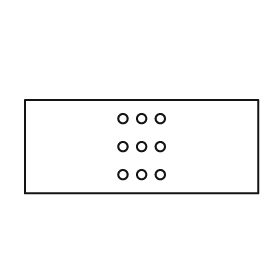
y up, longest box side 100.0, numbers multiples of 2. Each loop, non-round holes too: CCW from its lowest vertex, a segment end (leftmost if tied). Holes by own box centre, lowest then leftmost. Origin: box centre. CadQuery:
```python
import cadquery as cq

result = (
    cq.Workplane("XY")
    .moveTo(-50.0, -20.0)
    .lineTo(50.0, -20.0)
    .lineTo(50.0, 20.0)
    .lineTo(-50.0, 20.0)
    .close()
    .moveTo(-8.0, -12.0)
    .circle(2.0)
    .moveTo(0.0, -12.0)
    .circle(2.0)
    .moveTo(8.0, -12.0)
    .circle(2.0)
    .moveTo(-8.0, 0.0)
    .circle(2.0)
    .moveTo(0.0, 0.0)
    .circle(2.0)
    .moveTo(8.0, 0.0)
    .circle(2.0)
    .moveTo(-8.0, 12.0)
    .circle(2.0)
    .moveTo(0.0, 12.0)
    .circle(2.0)
    .moveTo(8.0, 12.0)
    .circle(2.0)
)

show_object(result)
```